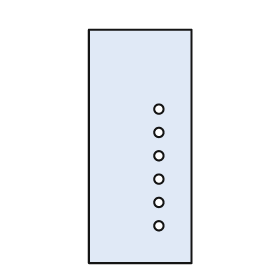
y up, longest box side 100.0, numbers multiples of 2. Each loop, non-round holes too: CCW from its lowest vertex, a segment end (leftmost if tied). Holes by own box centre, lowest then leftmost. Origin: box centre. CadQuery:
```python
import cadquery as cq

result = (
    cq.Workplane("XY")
    .moveTo(-22.0, -50.0)
    .lineTo(22.0, -50.0)
    .lineTo(22.0, 50.0)
    .lineTo(-22.0, 50.0)
    .close()
    .moveTo(8.0, -34.0)
    .circle(2.0)
    .moveTo(8.0, -24.0)
    .circle(2.0)
    .moveTo(8.0, -14.0)
    .circle(2.0)
    .moveTo(8.0, -4.0)
    .circle(2.0)
    .moveTo(8.0, 6.0)
    .circle(2.0)
    .moveTo(8.0, 16.0)
    .circle(2.0)
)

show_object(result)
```